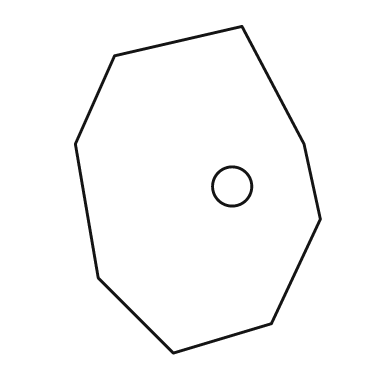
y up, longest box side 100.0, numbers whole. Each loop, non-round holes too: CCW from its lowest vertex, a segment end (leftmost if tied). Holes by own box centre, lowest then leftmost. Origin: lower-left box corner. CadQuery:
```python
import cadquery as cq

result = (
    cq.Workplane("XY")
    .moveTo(30.0, 0.0)
    .lineTo(60.0, 9.0)
    .lineTo(75.0, 41.0)
    .lineTo(70.0, 64.0)
    .lineTo(51.0, 100.0)
    .lineTo(12.0, 91.0)
    .lineTo(0.0, 64.0)
    .lineTo(7.0, 23.0)
    .close()
    .moveTo(48.0, 51.0)
    .circle(6.0)
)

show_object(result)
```